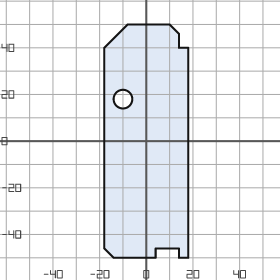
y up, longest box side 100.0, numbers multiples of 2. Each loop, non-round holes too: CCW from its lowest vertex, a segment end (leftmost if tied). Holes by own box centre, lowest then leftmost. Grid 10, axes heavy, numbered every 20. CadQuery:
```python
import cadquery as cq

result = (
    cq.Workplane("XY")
    .moveTo(-14.0, -50.0)
    .lineTo(4.0, -50.0)
    .lineTo(4.0, -46.0)
    .lineTo(14.0, -46.0)
    .lineTo(14.0, -50.0)
    .lineTo(18.0, -50.0)
    .lineTo(18.0, 40.0)
    .lineTo(14.0, 40.0)
    .lineTo(14.0, 46.0)
    .lineTo(10.0, 50.0)
    .lineTo(-8.0, 50.0)
    .lineTo(-18.0, 40.0)
    .lineTo(-18.0, -46.0)
    .close()
    .moveTo(-10.0, 18.0)
    .circle(4.0)
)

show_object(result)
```